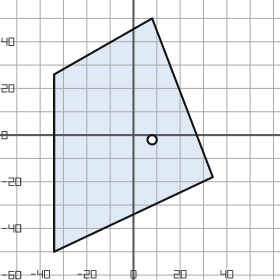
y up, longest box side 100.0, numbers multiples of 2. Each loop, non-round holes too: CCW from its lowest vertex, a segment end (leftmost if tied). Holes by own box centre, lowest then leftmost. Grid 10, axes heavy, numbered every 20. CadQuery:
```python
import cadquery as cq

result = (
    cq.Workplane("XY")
    .moveTo(-34.0, -50.0)
    .lineTo(34.0, -18.0)
    .lineTo(8.0, 50.0)
    .lineTo(-34.0, 26.0)
    .close()
    .moveTo(8.0, -2.0)
    .circle(2.0)
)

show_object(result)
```